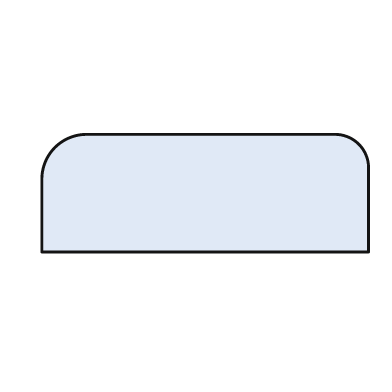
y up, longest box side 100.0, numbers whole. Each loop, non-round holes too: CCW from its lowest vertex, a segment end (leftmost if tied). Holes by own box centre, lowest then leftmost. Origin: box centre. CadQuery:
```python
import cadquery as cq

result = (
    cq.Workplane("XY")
    .moveTo(-50.0, -18.0)
    .lineTo(50.0, -18.0)
    .lineTo(50.0, 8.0)
    .threePointArc((47.0, 15.0), (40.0, 18.0))
    .lineTo(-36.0, 18.0)
    .threePointArc((-46.0, 14.0), (-50.0, 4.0))
    .close()
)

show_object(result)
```